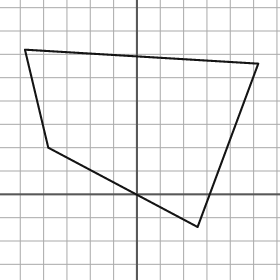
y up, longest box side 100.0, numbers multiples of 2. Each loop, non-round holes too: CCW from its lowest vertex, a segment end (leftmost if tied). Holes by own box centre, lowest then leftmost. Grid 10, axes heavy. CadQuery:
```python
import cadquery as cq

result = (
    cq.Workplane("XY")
    .moveTo(26.0, -14.0)
    .lineTo(52.0, 56.0)
    .lineTo(-48.0, 62.0)
    .lineTo(-38.0, 20.0)
    .close()
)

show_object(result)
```